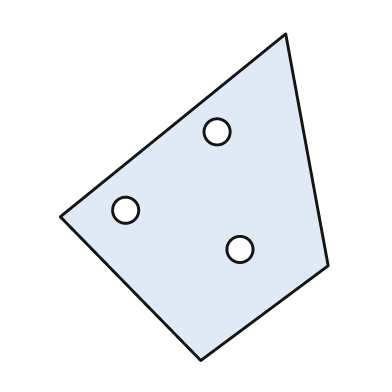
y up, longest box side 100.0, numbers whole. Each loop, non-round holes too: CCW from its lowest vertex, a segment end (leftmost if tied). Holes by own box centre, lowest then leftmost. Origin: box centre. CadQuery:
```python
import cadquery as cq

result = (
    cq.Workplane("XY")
    .moveTo(2.0, -50.0)
    .lineTo(41.0, -21.0)
    .lineTo(28.0, 50.0)
    .lineTo(-41.0, -6.0)
    .close()
    .moveTo(14.0, -16.0)
    .circle(4.0)
    .moveTo(-21.0, -4.0)
    .circle(4.0)
    .moveTo(7.0, 20.0)
    .circle(4.0)
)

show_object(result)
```